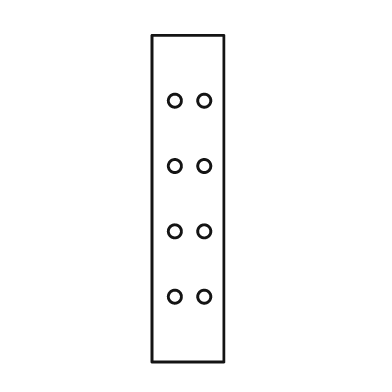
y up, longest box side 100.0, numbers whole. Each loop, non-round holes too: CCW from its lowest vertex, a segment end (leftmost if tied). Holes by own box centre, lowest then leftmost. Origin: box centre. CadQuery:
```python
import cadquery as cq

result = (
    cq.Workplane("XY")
    .moveTo(-11.0, -50.0)
    .lineTo(11.0, -50.0)
    .lineTo(11.0, 50.0)
    .lineTo(-11.0, 50.0)
    .close()
    .moveTo(-4.0, -30.0)
    .circle(2.0)
    .moveTo(5.0, -30.0)
    .circle(2.0)
    .moveTo(-4.0, -10.0)
    .circle(2.0)
    .moveTo(5.0, -10.0)
    .circle(2.0)
    .moveTo(-4.0, 10.0)
    .circle(2.0)
    .moveTo(5.0, 10.0)
    .circle(2.0)
    .moveTo(-4.0, 30.0)
    .circle(2.0)
    .moveTo(5.0, 30.0)
    .circle(2.0)
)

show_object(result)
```